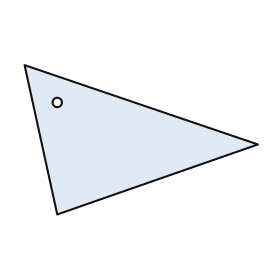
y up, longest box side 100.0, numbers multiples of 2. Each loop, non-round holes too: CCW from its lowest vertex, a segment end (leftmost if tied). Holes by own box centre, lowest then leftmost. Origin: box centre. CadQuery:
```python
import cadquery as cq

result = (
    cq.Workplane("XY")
    .moveTo(-36.0, -32.0)
    .lineTo(50.0, -2.0)
    .lineTo(-50.0, 32.0)
    .close()
    .moveTo(-36.0, 16.0)
    .circle(2.0)
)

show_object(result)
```